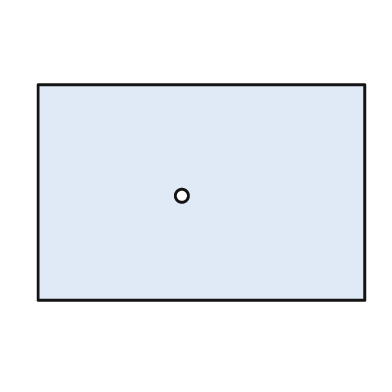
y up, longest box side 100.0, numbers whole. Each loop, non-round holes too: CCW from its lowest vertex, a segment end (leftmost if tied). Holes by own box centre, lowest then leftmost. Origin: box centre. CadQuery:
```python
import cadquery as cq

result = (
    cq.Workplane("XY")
    .moveTo(-50.0, -33.0)
    .lineTo(50.0, -33.0)
    .lineTo(50.0, 33.0)
    .lineTo(-50.0, 33.0)
    .close()
    .moveTo(-6.0, -1.0)
    .circle(2.0)
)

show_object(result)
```